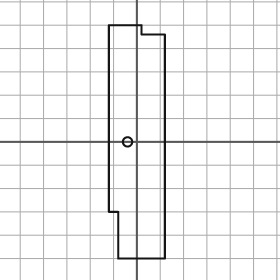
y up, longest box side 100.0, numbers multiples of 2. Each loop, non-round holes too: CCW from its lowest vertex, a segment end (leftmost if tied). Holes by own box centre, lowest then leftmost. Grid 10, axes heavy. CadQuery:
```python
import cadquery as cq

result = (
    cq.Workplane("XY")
    .moveTo(-8.0, -50.0)
    .lineTo(12.0, -50.0)
    .lineTo(12.0, 46.0)
    .lineTo(2.0, 46.0)
    .lineTo(2.0, 50.0)
    .lineTo(-12.0, 50.0)
    .lineTo(-12.0, -30.0)
    .lineTo(-8.0, -30.0)
    .close()
    .moveTo(-4.0, 0.0)
    .circle(2.0)
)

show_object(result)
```